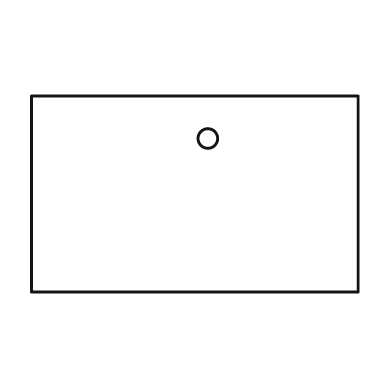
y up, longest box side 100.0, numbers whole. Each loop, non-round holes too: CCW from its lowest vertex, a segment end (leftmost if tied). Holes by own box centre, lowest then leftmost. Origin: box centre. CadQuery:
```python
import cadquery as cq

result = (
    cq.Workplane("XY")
    .moveTo(-50.0, -30.0)
    .lineTo(50.0, -30.0)
    .lineTo(50.0, 30.0)
    .lineTo(-50.0, 30.0)
    .close()
    .moveTo(4.0, 17.0)
    .circle(3.0)
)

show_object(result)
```